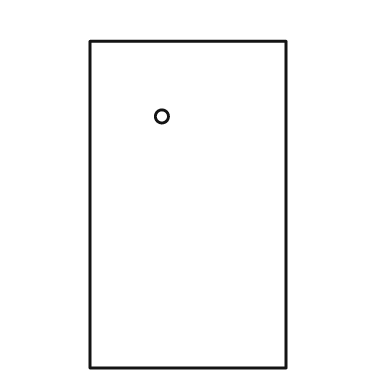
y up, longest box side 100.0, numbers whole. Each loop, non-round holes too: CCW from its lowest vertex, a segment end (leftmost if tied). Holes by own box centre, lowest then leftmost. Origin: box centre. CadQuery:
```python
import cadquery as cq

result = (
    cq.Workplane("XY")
    .moveTo(-30.0, -50.0)
    .lineTo(30.0, -50.0)
    .lineTo(30.0, 50.0)
    .lineTo(-30.0, 50.0)
    .close()
    .moveTo(-8.0, 27.0)
    .circle(2.0)
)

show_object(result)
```